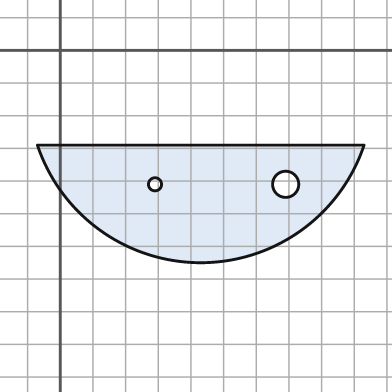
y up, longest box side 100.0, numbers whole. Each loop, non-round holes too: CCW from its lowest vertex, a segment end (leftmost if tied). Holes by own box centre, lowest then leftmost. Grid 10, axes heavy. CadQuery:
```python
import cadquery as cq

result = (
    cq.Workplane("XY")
    .moveTo(-7.0, -29.0)
    .threePointArc((43.0, -65.0), (93.0, -29.0))
    .close()
    .moveTo(29.0, -41.0)
    .circle(2.0)
    .moveTo(69.0, -41.0)
    .circle(4.0)
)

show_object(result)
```